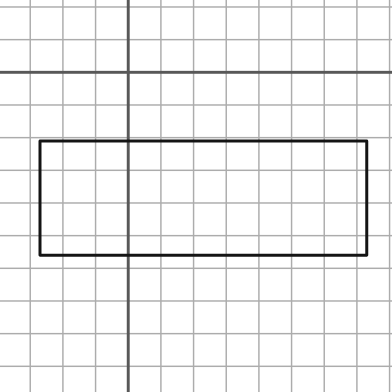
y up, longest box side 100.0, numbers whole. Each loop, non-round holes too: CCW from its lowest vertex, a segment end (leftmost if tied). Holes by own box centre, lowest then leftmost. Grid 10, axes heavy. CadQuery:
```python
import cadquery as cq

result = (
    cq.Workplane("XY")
    .moveTo(-27.0, -56.0)
    .lineTo(73.0, -56.0)
    .lineTo(73.0, -21.0)
    .lineTo(-27.0, -21.0)
    .close()
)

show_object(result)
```